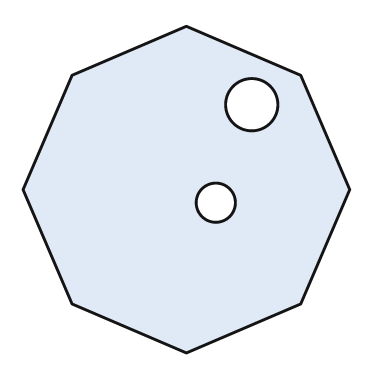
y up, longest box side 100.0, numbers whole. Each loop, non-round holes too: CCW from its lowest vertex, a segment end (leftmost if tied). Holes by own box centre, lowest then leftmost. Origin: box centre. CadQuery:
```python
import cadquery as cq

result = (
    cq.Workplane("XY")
    .moveTo(0.0, -50.0)
    .lineTo(35.0, -35.0)
    .lineTo(50.0, 0.0)
    .lineTo(35.0, 35.0)
    .lineTo(0.0, 50.0)
    .lineTo(-35.0, 35.0)
    .lineTo(-50.0, 0.0)
    .lineTo(-35.0, -35.0)
    .close()
    .moveTo(9.0, -4.0)
    .circle(6.0)
    .moveTo(20.0, 26.0)
    .circle(8.0)
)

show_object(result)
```